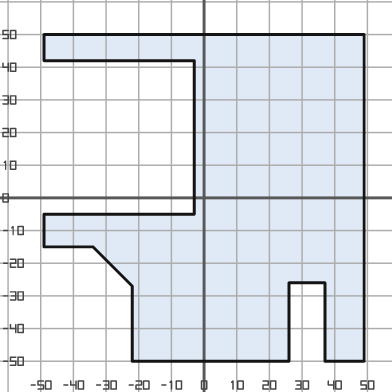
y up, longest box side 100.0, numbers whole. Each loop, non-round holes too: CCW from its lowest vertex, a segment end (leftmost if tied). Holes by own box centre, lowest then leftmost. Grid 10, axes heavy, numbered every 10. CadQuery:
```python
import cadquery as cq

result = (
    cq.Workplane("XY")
    .moveTo(-22.0, -50.0)
    .lineTo(26.0, -50.0)
    .lineTo(26.0, -26.0)
    .lineTo(37.0, -26.0)
    .lineTo(37.0, -50.0)
    .lineTo(49.0, -50.0)
    .lineTo(49.0, 50.0)
    .lineTo(-49.0, 50.0)
    .lineTo(-49.0, 42.0)
    .lineTo(-3.0, 42.0)
    .lineTo(-3.0, -5.0)
    .lineTo(-49.0, -5.0)
    .lineTo(-49.0, -15.0)
    .lineTo(-34.0, -15.0)
    .lineTo(-22.0, -27.0)
    .close()
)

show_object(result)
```